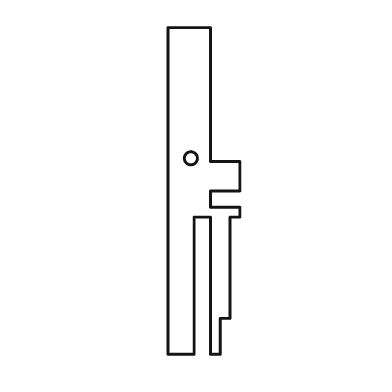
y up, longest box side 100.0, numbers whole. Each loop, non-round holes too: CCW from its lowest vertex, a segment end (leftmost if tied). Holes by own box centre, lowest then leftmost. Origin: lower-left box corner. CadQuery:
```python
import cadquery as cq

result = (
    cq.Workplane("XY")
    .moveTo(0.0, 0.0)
    .lineTo(8.0, 0.0)
    .lineTo(8.0, 42.0)
    .lineTo(13.0, 42.0)
    .lineTo(13.0, 0.0)
    .lineTo(16.0, 0.0)
    .lineTo(16.0, 11.0)
    .lineTo(19.0, 11.0)
    .lineTo(19.0, 42.0)
    .lineTo(22.0, 42.0)
    .lineTo(22.0, 45.0)
    .lineTo(13.0, 45.0)
    .lineTo(13.0, 50.0)
    .lineTo(22.0, 50.0)
    .lineTo(22.0, 59.0)
    .lineTo(13.0, 59.0)
    .lineTo(13.0, 100.0)
    .lineTo(0.0, 100.0)
    .close()
    .moveTo(7.0, 60.0)
    .circle(2.0)
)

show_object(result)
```